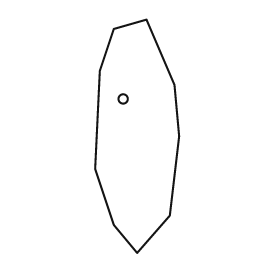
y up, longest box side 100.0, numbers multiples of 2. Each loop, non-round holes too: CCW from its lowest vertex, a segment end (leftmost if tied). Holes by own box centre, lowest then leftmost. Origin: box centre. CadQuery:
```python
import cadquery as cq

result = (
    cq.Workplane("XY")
    .moveTo(0.0, -50.0)
    .lineTo(14.0, -34.0)
    .lineTo(18.0, 0.0)
    .lineTo(16.0, 22.0)
    .lineTo(4.0, 50.0)
    .lineTo(-10.0, 46.0)
    .lineTo(-16.0, 28.0)
    .lineTo(-18.0, -14.0)
    .lineTo(-10.0, -38.0)
    .close()
    .moveTo(-6.0, 16.0)
    .circle(2.0)
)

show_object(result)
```